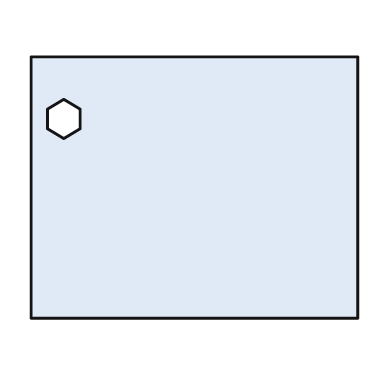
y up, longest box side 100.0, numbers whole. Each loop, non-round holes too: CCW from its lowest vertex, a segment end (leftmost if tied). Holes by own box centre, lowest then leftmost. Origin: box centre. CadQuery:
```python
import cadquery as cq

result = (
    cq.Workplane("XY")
    .moveTo(-50.0, -40.0)
    .lineTo(50.0, -40.0)
    .lineTo(50.0, 40.0)
    .lineTo(-50.0, 40.0)
    .close()
    .moveTo(-40.0, 15.0)
    .lineTo(-35.0, 18.0)
    .lineTo(-35.0, 24.0)
    .lineTo(-40.0, 27.0)
    .lineTo(-45.0, 24.0)
    .lineTo(-45.0, 18.0)
    .close()
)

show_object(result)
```